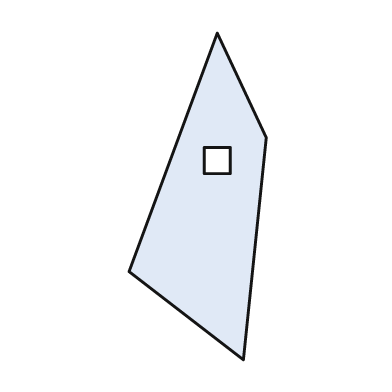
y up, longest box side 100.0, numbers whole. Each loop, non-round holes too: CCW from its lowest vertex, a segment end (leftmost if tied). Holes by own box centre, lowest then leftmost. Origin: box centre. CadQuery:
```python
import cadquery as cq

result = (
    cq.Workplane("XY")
    .moveTo(14.0, -50.0)
    .lineTo(21.0, 18.0)
    .lineTo(6.0, 50.0)
    .lineTo(-21.0, -23.0)
    .close()
    .moveTo(2.0, 7.0)
    .lineTo(10.0, 7.0)
    .lineTo(10.0, 15.0)
    .lineTo(2.0, 15.0)
    .close()
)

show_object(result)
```